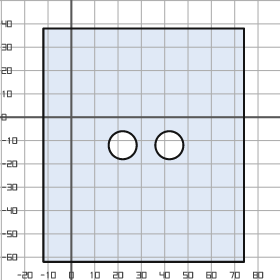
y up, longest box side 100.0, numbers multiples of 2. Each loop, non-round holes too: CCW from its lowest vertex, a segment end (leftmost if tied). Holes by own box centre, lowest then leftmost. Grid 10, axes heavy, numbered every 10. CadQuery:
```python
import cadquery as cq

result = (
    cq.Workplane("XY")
    .moveTo(-12.0, -62.0)
    .lineTo(74.0, -62.0)
    .lineTo(74.0, 38.0)
    .lineTo(-12.0, 38.0)
    .close()
    .moveTo(22.0, -12.0)
    .circle(6.0)
    .moveTo(42.0, -12.0)
    .circle(6.0)
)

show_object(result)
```